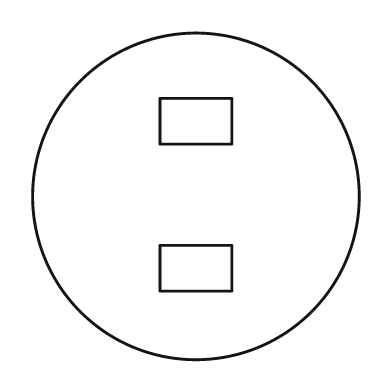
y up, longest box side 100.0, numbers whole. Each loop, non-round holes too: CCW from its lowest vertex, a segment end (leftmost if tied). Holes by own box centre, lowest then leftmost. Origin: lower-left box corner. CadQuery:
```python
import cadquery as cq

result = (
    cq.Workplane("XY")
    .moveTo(50.0, 50.0)
    .circle(50.0)
    .moveTo(39.0, 21.0)
    .lineTo(61.0, 21.0)
    .lineTo(61.0, 35.0)
    .lineTo(39.0, 35.0)
    .close()
    .moveTo(39.0, 66.0)
    .lineTo(61.0, 66.0)
    .lineTo(61.0, 80.0)
    .lineTo(39.0, 80.0)
    .close()
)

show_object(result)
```